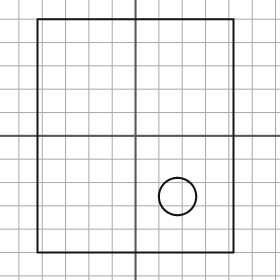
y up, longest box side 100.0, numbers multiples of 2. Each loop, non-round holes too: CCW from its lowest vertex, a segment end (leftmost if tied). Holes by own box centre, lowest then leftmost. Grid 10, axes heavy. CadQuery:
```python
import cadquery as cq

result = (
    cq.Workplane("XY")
    .moveTo(-42.0, -50.0)
    .lineTo(42.0, -50.0)
    .lineTo(42.0, 50.0)
    .lineTo(-42.0, 50.0)
    .close()
    .moveTo(18.0, -26.0)
    .circle(8.0)
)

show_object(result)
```